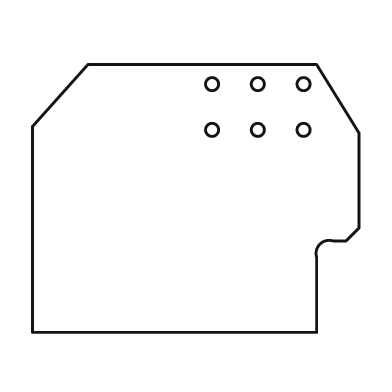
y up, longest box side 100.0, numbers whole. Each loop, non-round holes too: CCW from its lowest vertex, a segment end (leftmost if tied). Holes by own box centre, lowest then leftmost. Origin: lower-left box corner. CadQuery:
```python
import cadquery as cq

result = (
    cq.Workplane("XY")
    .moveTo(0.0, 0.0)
    .lineTo(87.0, 0.0)
    .lineTo(87.0, 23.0)
    .threePointArc((88.0, 27.0), (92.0, 28.0))
    .lineTo(96.0, 28.0)
    .lineTo(100.0, 32.0)
    .lineTo(100.0, 61.0)
    .lineTo(87.0, 82.0)
    .lineTo(17.0, 82.0)
    .lineTo(0.0, 63.0)
    .close()
    .moveTo(55.0, 62.0)
    .circle(2.0)
    .moveTo(69.0, 62.0)
    .circle(2.0)
    .moveTo(83.0, 62.0)
    .circle(2.0)
    .moveTo(55.0, 76.0)
    .circle(2.0)
    .moveTo(69.0, 76.0)
    .circle(2.0)
    .moveTo(83.0, 76.0)
    .circle(2.0)
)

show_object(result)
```